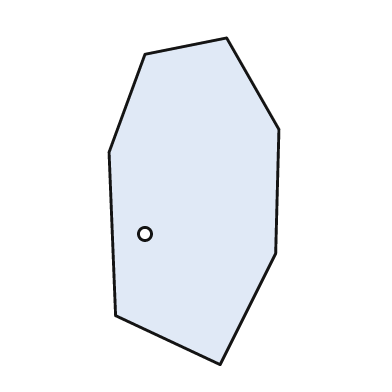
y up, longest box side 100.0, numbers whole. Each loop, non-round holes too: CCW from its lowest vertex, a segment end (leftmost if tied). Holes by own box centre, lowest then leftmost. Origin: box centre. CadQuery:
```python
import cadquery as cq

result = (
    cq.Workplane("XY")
    .moveTo(8.0, -50.0)
    .lineTo(25.0, -16.0)
    .lineTo(26.0, 22.0)
    .lineTo(10.0, 50.0)
    .lineTo(-15.0, 45.0)
    .lineTo(-26.0, 15.0)
    .lineTo(-24.0, -35.0)
    .close()
    .moveTo(-15.0, -10.0)
    .circle(2.0)
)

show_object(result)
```